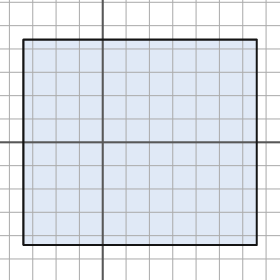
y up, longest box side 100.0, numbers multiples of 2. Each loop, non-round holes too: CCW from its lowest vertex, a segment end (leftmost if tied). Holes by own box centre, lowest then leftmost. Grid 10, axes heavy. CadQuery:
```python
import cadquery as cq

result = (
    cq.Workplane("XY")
    .moveTo(-34.0, -44.0)
    .lineTo(66.0, -44.0)
    .lineTo(66.0, 44.0)
    .lineTo(-34.0, 44.0)
    .close()
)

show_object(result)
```